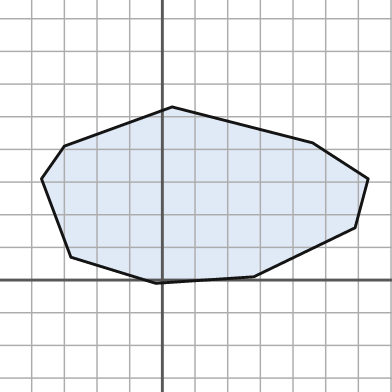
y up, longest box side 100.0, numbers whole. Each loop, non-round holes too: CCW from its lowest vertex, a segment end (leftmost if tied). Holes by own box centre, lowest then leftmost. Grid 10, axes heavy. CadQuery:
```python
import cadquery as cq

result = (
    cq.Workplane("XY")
    .moveTo(-2.0, -1.0)
    .lineTo(28.0, 1.0)
    .lineTo(59.0, 16.0)
    .lineTo(63.0, 31.0)
    .lineTo(46.0, 42.0)
    .lineTo(3.0, 53.0)
    .lineTo(-30.0, 41.0)
    .lineTo(-37.0, 31.0)
    .lineTo(-28.0, 7.0)
    .close()
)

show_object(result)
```